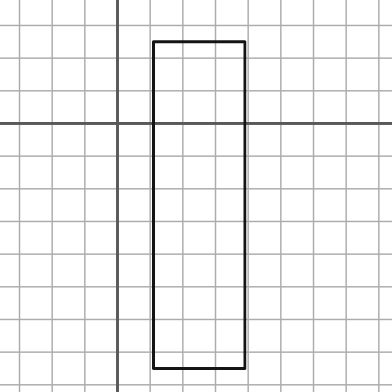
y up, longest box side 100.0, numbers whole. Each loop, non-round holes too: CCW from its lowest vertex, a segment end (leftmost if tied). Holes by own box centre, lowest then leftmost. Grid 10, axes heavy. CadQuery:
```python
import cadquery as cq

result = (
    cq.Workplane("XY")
    .moveTo(11.0, -75.0)
    .lineTo(39.0, -75.0)
    .lineTo(39.0, 25.0)
    .lineTo(11.0, 25.0)
    .close()
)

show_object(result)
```